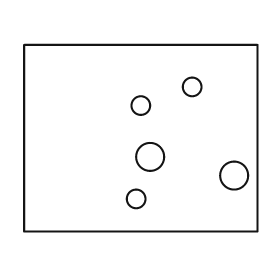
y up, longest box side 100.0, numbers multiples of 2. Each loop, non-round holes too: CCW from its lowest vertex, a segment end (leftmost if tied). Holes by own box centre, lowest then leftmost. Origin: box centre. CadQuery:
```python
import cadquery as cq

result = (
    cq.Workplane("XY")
    .moveTo(-50.0, -40.0)
    .lineTo(50.0, -40.0)
    .lineTo(50.0, 40.0)
    .lineTo(-50.0, 40.0)
    .close()
    .moveTo(-2.0, -26.0)
    .circle(4.0)
    .moveTo(40.0, -16.0)
    .circle(6.0)
    .moveTo(4.0, -8.0)
    .circle(6.0)
    .moveTo(0.0, 14.0)
    .circle(4.0)
    .moveTo(22.0, 22.0)
    .circle(4.0)
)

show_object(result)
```